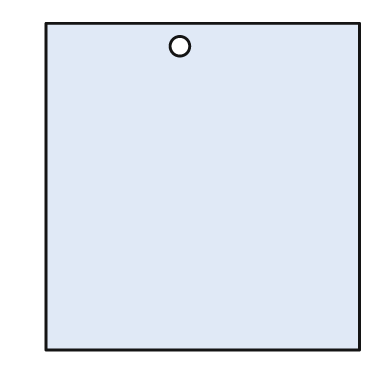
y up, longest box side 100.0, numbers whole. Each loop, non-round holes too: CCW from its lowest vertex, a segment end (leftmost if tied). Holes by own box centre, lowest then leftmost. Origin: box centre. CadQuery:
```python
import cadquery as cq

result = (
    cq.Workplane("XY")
    .moveTo(-48.0, -50.0)
    .lineTo(48.0, -50.0)
    .lineTo(48.0, 50.0)
    .lineTo(-48.0, 50.0)
    .close()
    .moveTo(-7.0, 43.0)
    .circle(3.0)
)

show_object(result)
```